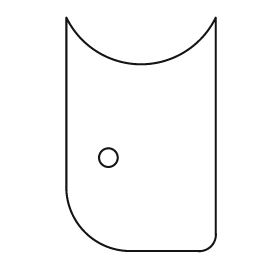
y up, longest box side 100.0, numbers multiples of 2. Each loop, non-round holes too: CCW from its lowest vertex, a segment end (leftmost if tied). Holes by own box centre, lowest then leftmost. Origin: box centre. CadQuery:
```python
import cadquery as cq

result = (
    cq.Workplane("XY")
    .moveTo(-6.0, -50.0)
    .lineTo(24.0, -50.0)
    .threePointArc((30.0, -48.0), (32.0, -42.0))
    .lineTo(32.0, 50.0)
    .threePointArc((0.0, 30.0), (-32.0, 50.0))
    .lineTo(-32.0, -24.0)
    .threePointArc((-24.0, -42.0), (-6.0, -50.0))
    .close()
    .moveTo(-14.0, -10.0)
    .circle(4.0)
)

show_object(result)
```